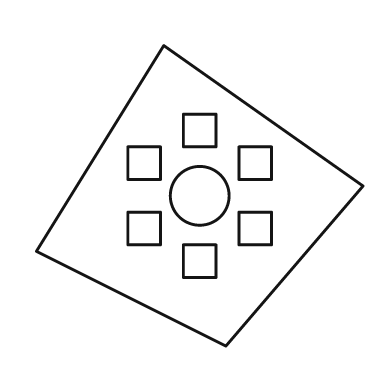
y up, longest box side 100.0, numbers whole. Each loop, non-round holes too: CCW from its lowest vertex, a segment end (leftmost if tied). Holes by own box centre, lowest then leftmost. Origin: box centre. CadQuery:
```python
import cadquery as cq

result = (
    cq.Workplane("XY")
    .moveTo(8.0, -46.0)
    .lineTo(50.0, 3.0)
    .lineTo(-11.0, 46.0)
    .lineTo(-50.0, -17.0)
    .close()
    .moveTo(-5.0, -25.0)
    .lineTo(5.0, -25.0)
    .lineTo(5.0, -15.0)
    .lineTo(-5.0, -15.0)
    .close()
    .moveTo(-22.0, -15.0)
    .lineTo(-12.0, -15.0)
    .lineTo(-12.0, -5.0)
    .lineTo(-22.0, -5.0)
    .close()
    .moveTo(12.0, -15.0)
    .lineTo(22.0, -15.0)
    .lineTo(22.0, -5.0)
    .lineTo(12.0, -5.0)
    .close()
    .moveTo(0.0, 0.0)
    .circle(9.0)
    .moveTo(-22.0, 5.0)
    .lineTo(-12.0, 5.0)
    .lineTo(-12.0, 15.0)
    .lineTo(-22.0, 15.0)
    .close()
    .moveTo(12.0, 5.0)
    .lineTo(22.0, 5.0)
    .lineTo(22.0, 15.0)
    .lineTo(12.0, 15.0)
    .close()
    .moveTo(-5.0, 15.0)
    .lineTo(5.0, 15.0)
    .lineTo(5.0, 25.0)
    .lineTo(-5.0, 25.0)
    .close()
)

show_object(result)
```